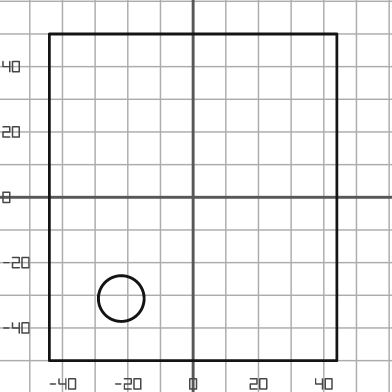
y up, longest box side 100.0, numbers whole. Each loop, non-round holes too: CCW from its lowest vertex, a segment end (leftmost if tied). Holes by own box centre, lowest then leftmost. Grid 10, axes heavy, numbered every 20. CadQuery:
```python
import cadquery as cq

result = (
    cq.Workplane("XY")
    .moveTo(-44.0, -50.0)
    .lineTo(44.0, -50.0)
    .lineTo(44.0, 50.0)
    .lineTo(-44.0, 50.0)
    .close()
    .moveTo(-22.0, -31.0)
    .circle(7.0)
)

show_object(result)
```